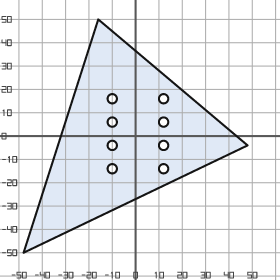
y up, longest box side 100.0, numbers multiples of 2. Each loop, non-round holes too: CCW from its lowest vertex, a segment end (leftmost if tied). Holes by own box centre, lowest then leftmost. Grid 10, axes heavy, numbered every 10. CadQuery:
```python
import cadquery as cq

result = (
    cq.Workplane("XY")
    .moveTo(-48.0, -50.0)
    .lineTo(48.0, -4.0)
    .lineTo(-16.0, 50.0)
    .close()
    .moveTo(-10.0, -14.0)
    .circle(2.0)
    .moveTo(12.0, -14.0)
    .circle(2.0)
    .moveTo(-10.0, -4.0)
    .circle(2.0)
    .moveTo(12.0, -4.0)
    .circle(2.0)
    .moveTo(-10.0, 6.0)
    .circle(2.0)
    .moveTo(12.0, 6.0)
    .circle(2.0)
    .moveTo(-10.0, 16.0)
    .circle(2.0)
    .moveTo(12.0, 16.0)
    .circle(2.0)
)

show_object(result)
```